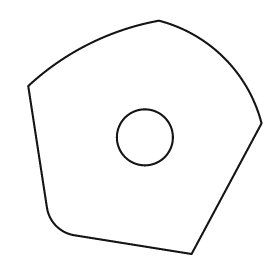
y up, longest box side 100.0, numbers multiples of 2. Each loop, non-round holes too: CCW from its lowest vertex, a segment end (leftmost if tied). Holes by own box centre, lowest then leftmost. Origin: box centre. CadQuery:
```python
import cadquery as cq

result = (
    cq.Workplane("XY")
    .moveTo(20.0, -50.0)
    .lineTo(50.0, 6.0)
    .threePointArc((34.0, 34.0), (6.0, 50.0))
    .threePointArc((-24.0, 40.0), (-50.0, 22.0))
    .lineTo(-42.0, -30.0)
    .threePointArc((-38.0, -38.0), (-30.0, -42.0))
    .close()
    .moveTo(0.0, 0.0)
    .circle(12.0)
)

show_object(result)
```